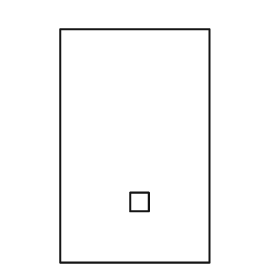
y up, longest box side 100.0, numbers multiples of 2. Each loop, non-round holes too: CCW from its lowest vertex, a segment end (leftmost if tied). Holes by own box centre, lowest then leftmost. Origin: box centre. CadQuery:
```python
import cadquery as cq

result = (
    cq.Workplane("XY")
    .moveTo(-32.0, -50.0)
    .lineTo(32.0, -50.0)
    .lineTo(32.0, 50.0)
    .lineTo(-32.0, 50.0)
    .close()
    .moveTo(-2.0, -28.0)
    .lineTo(6.0, -28.0)
    .lineTo(6.0, -20.0)
    .lineTo(-2.0, -20.0)
    .close()
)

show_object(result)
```